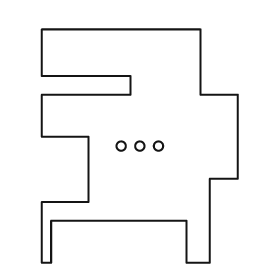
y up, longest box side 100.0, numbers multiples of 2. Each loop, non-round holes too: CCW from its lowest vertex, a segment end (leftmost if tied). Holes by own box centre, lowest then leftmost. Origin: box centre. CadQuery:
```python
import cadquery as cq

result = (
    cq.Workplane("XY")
    .moveTo(-42.0, -50.0)
    .lineTo(-38.0, -50.0)
    .lineTo(-38.0, -32.0)
    .lineTo(20.0, -32.0)
    .lineTo(20.0, -50.0)
    .lineTo(30.0, -50.0)
    .lineTo(30.0, -14.0)
    .lineTo(42.0, -14.0)
    .lineTo(42.0, 22.0)
    .lineTo(26.0, 22.0)
    .lineTo(26.0, 50.0)
    .lineTo(-42.0, 50.0)
    .lineTo(-42.0, 30.0)
    .lineTo(-4.0, 30.0)
    .lineTo(-4.0, 22.0)
    .lineTo(-42.0, 22.0)
    .lineTo(-42.0, 4.0)
    .lineTo(-22.0, 4.0)
    .lineTo(-22.0, -24.0)
    .lineTo(-42.0, -24.0)
    .close()
    .moveTo(-8.0, 0.0)
    .circle(2.0)
    .moveTo(0.0, 0.0)
    .circle(2.0)
    .moveTo(8.0, 0.0)
    .circle(2.0)
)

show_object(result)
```